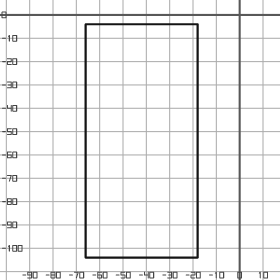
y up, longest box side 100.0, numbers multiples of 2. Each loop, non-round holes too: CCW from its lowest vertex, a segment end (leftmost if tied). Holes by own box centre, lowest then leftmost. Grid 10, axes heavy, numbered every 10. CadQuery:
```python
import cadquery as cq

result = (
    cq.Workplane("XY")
    .moveTo(-66.0, -104.0)
    .lineTo(-18.0, -104.0)
    .lineTo(-18.0, -4.0)
    .lineTo(-66.0, -4.0)
    .close()
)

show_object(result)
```